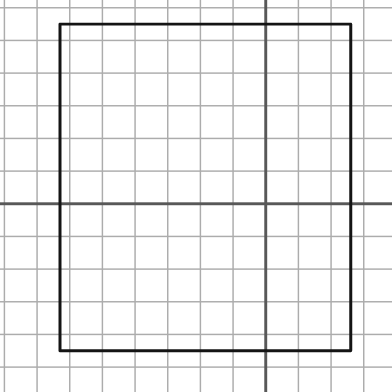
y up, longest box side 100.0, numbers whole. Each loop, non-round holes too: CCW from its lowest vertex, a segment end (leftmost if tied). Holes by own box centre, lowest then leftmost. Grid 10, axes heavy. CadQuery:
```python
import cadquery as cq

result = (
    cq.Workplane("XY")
    .moveTo(-63.0, -45.0)
    .lineTo(26.0, -45.0)
    .lineTo(26.0, 55.0)
    .lineTo(-63.0, 55.0)
    .close()
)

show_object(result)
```